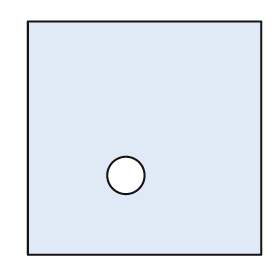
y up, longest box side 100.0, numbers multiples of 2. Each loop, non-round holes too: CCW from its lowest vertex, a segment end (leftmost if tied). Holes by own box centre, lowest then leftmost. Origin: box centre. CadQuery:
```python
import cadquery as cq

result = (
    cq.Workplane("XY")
    .moveTo(-50.0, -50.0)
    .lineTo(50.0, -50.0)
    .lineTo(50.0, 50.0)
    .lineTo(-50.0, 50.0)
    .close()
    .moveTo(-8.0, -16.0)
    .circle(8.0)
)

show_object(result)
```